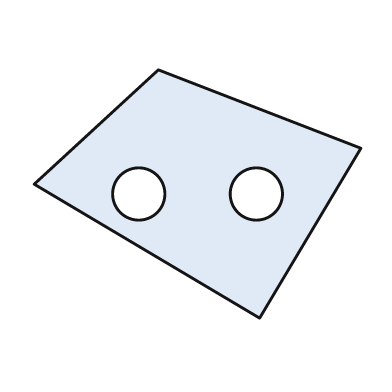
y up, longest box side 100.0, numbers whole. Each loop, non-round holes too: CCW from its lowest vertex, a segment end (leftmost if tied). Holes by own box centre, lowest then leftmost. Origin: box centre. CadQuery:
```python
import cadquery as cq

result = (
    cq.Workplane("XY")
    .moveTo(19.0, -38.0)
    .lineTo(50.0, 14.0)
    .lineTo(-12.0, 38.0)
    .lineTo(-50.0, 3.0)
    .close()
    .moveTo(-18.0, 0.0)
    .circle(8.0)
    .moveTo(18.0, 0.0)
    .circle(8.0)
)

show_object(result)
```